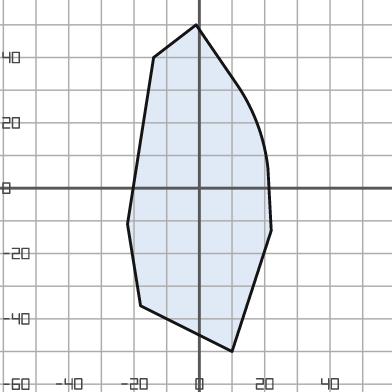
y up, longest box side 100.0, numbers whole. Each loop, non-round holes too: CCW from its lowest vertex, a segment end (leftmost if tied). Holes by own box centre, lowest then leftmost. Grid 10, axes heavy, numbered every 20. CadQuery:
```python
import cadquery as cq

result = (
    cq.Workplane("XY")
    .moveTo(10.0, -50.0)
    .lineTo(22.0, -13.0)
    .lineTo(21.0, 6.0)
    .threePointArc((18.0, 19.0), (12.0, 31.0))
    .lineTo(-1.0, 50.0)
    .lineTo(-14.0, 40.0)
    .lineTo(-22.0, -11.0)
    .lineTo(-18.0, -36.0)
    .close()
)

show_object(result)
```